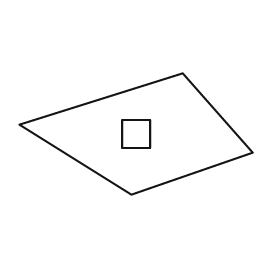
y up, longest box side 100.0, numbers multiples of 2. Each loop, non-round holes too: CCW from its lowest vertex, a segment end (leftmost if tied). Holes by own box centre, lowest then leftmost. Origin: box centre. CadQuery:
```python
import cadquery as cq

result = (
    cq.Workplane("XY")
    .moveTo(-2.0, -26.0)
    .lineTo(50.0, -8.0)
    .lineTo(20.0, 26.0)
    .lineTo(-50.0, 4.0)
    .close()
    .moveTo(-6.0, -6.0)
    .lineTo(6.0, -6.0)
    .lineTo(6.0, 6.0)
    .lineTo(-6.0, 6.0)
    .close()
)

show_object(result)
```